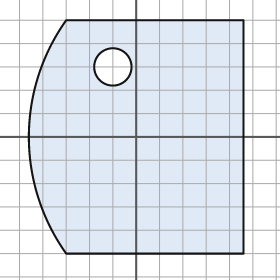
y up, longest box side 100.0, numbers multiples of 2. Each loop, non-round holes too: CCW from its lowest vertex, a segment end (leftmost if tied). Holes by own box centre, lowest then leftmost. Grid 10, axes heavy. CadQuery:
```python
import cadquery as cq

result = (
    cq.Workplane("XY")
    .moveTo(-30.0, -50.0)
    .lineTo(46.0, -50.0)
    .lineTo(46.0, 50.0)
    .lineTo(-30.0, 50.0)
    .threePointArc((-46.0, 0.0), (-30.0, -50.0))
    .close()
    .moveTo(-10.0, 30.0)
    .circle(8.0)
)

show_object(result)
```